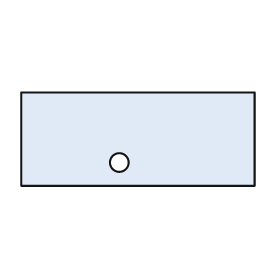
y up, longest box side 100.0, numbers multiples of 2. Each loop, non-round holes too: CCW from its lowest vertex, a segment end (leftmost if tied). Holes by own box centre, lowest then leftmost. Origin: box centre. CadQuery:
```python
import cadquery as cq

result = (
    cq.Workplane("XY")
    .moveTo(-50.0, -20.0)
    .lineTo(50.0, -20.0)
    .lineTo(50.0, 20.0)
    .lineTo(-50.0, 20.0)
    .close()
    .moveTo(-8.0, -10.0)
    .circle(4.0)
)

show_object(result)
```